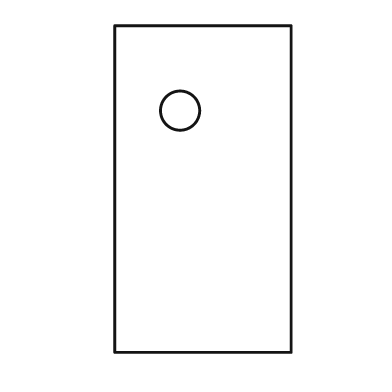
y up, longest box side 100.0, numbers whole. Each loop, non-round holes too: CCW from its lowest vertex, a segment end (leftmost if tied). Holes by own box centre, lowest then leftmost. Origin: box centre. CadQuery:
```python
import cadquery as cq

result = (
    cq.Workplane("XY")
    .moveTo(-27.0, -50.0)
    .lineTo(27.0, -50.0)
    .lineTo(27.0, 50.0)
    .lineTo(-27.0, 50.0)
    .close()
    .moveTo(-7.0, 24.0)
    .circle(6.0)
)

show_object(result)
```